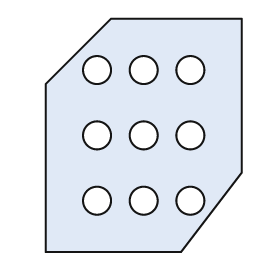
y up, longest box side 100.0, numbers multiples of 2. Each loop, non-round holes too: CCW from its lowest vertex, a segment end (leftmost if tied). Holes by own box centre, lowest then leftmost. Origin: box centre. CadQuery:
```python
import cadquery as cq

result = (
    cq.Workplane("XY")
    .moveTo(-42.0, -50.0)
    .lineTo(16.0, -50.0)
    .lineTo(42.0, -16.0)
    .lineTo(42.0, 50.0)
    .lineTo(-14.0, 50.0)
    .lineTo(-42.0, 22.0)
    .close()
    .moveTo(-20.0, -28.0)
    .circle(6.0)
    .moveTo(0.0, -28.0)
    .circle(6.0)
    .moveTo(20.0, -28.0)
    .circle(6.0)
    .moveTo(-20.0, 0.0)
    .circle(6.0)
    .moveTo(0.0, 0.0)
    .circle(6.0)
    .moveTo(20.0, 0.0)
    .circle(6.0)
    .moveTo(-20.0, 28.0)
    .circle(6.0)
    .moveTo(0.0, 28.0)
    .circle(6.0)
    .moveTo(20.0, 28.0)
    .circle(6.0)
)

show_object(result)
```